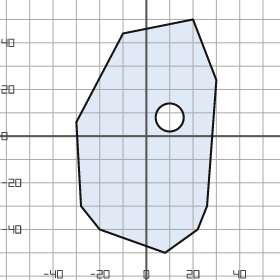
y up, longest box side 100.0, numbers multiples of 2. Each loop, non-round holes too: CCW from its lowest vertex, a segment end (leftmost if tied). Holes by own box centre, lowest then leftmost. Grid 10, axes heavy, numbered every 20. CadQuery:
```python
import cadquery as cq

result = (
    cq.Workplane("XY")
    .moveTo(8.0, -50.0)
    .lineTo(22.0, -40.0)
    .lineTo(26.0, -30.0)
    .lineTo(30.0, 24.0)
    .lineTo(20.0, 50.0)
    .lineTo(-10.0, 44.0)
    .lineTo(-30.0, 6.0)
    .lineTo(-28.0, -30.0)
    .lineTo(-20.0, -40.0)
    .close()
    .moveTo(10.0, 8.0)
    .circle(6.0)
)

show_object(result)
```